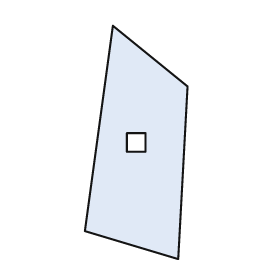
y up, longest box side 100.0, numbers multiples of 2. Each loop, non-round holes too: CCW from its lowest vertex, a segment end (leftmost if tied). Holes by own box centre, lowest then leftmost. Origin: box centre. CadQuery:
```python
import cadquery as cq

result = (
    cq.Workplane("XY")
    .moveTo(18.0, -50.0)
    .lineTo(22.0, 24.0)
    .lineTo(-10.0, 50.0)
    .lineTo(-22.0, -38.0)
    .close()
    .moveTo(-4.0, -4.0)
    .lineTo(4.0, -4.0)
    .lineTo(4.0, 4.0)
    .lineTo(-4.0, 4.0)
    .close()
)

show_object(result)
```